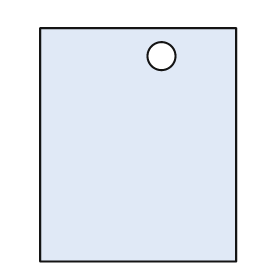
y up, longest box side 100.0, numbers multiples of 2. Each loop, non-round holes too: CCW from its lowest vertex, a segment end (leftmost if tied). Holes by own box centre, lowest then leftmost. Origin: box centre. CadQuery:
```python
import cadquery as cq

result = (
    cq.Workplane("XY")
    .moveTo(-42.0, -50.0)
    .lineTo(42.0, -50.0)
    .lineTo(42.0, 50.0)
    .lineTo(-42.0, 50.0)
    .close()
    .moveTo(10.0, 38.0)
    .circle(6.0)
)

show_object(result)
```